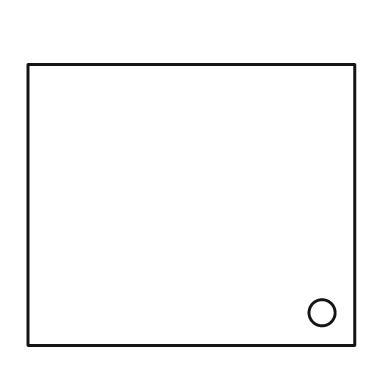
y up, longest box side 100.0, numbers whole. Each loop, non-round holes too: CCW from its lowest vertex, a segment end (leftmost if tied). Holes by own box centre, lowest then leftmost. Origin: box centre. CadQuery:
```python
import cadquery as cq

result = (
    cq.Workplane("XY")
    .moveTo(-50.0, -43.0)
    .lineTo(50.0, -43.0)
    .lineTo(50.0, 43.0)
    .lineTo(-50.0, 43.0)
    .close()
    .moveTo(40.0, -33.0)
    .circle(4.0)
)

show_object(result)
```